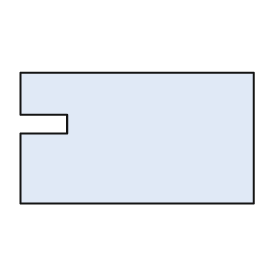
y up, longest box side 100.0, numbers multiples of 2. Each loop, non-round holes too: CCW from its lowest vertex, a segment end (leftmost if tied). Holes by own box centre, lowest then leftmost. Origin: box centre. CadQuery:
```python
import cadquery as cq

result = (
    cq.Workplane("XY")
    .moveTo(-50.0, -28.0)
    .lineTo(50.0, -28.0)
    .lineTo(50.0, 28.0)
    .lineTo(-50.0, 28.0)
    .lineTo(-50.0, 10.0)
    .lineTo(-30.0, 10.0)
    .lineTo(-30.0, 2.0)
    .lineTo(-50.0, 2.0)
    .close()
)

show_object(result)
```